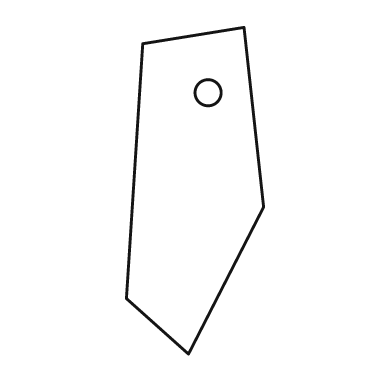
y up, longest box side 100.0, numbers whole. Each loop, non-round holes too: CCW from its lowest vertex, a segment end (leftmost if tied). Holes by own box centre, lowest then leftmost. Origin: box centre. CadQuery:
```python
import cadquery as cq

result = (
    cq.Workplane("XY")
    .moveTo(-2.0, -50.0)
    .lineTo(21.0, -5.0)
    .lineTo(15.0, 50.0)
    .lineTo(-16.0, 45.0)
    .lineTo(-21.0, -33.0)
    .close()
    .moveTo(4.0, 30.0)
    .circle(4.0)
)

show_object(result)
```